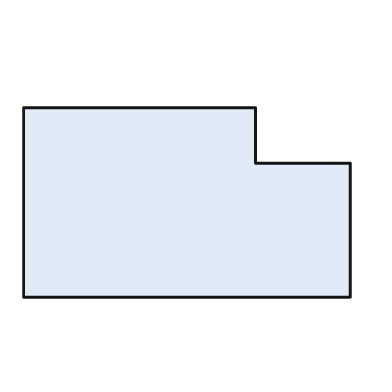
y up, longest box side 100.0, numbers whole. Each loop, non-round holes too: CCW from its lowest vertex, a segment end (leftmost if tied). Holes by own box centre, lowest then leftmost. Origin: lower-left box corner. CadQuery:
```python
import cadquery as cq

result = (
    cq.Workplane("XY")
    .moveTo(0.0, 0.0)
    .lineTo(100.0, 0.0)
    .lineTo(100.0, 41.0)
    .lineTo(71.0, 41.0)
    .lineTo(71.0, 58.0)
    .lineTo(0.0, 58.0)
    .close()
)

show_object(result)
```